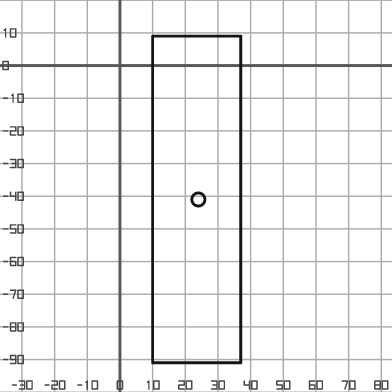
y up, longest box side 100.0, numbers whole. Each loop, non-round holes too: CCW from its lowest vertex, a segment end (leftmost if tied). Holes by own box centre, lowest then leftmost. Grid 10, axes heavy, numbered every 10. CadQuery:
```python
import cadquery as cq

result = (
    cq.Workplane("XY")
    .moveTo(10.0, -91.0)
    .lineTo(37.0, -91.0)
    .lineTo(37.0, 9.0)
    .lineTo(10.0, 9.0)
    .close()
    .moveTo(24.0, -41.0)
    .circle(2.0)
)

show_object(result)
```